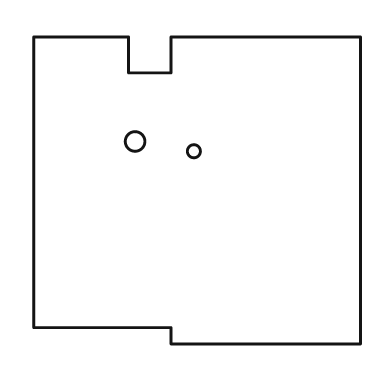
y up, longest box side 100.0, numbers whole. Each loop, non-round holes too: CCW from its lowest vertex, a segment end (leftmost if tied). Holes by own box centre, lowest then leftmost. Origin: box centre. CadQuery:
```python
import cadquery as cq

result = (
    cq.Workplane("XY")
    .moveTo(-8.0, -47.0)
    .lineTo(50.0, -47.0)
    .lineTo(50.0, 47.0)
    .lineTo(-8.0, 47.0)
    .lineTo(-8.0, 36.0)
    .lineTo(-21.0, 36.0)
    .lineTo(-21.0, 47.0)
    .lineTo(-50.0, 47.0)
    .lineTo(-50.0, -42.0)
    .lineTo(-8.0, -42.0)
    .close()
    .moveTo(-1.0, 12.0)
    .circle(2.0)
    .moveTo(-19.0, 15.0)
    .circle(3.0)
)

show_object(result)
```